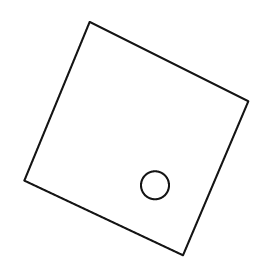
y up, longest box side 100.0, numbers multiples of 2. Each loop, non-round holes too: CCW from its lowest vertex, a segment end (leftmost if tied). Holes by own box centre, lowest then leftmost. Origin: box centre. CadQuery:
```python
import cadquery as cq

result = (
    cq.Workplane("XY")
    .moveTo(20.0, -50.0)
    .lineTo(48.0, 16.0)
    .lineTo(-20.0, 50.0)
    .lineTo(-48.0, -18.0)
    .close()
    .moveTo(8.0, -20.0)
    .circle(6.0)
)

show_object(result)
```